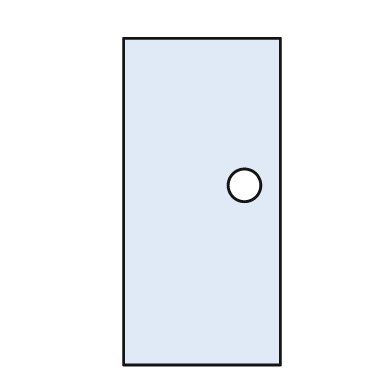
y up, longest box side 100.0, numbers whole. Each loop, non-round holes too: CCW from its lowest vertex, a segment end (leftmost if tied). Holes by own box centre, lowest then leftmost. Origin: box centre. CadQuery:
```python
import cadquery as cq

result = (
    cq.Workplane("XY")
    .moveTo(-24.0, -50.0)
    .lineTo(24.0, -50.0)
    .lineTo(24.0, 50.0)
    .lineTo(-24.0, 50.0)
    .close()
    .moveTo(13.0, 5.0)
    .circle(5.0)
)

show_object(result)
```